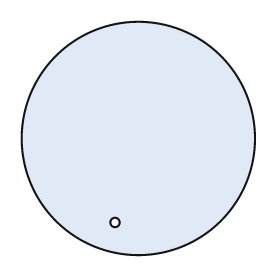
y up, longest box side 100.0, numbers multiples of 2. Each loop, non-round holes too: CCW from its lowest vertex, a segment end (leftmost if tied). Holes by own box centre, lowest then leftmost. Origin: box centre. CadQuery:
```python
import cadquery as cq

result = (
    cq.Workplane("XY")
    .moveTo(0.0, 0.0)
    .circle(50.0)
    .moveTo(-10.0, -36.0)
    .circle(2.0)
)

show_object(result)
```